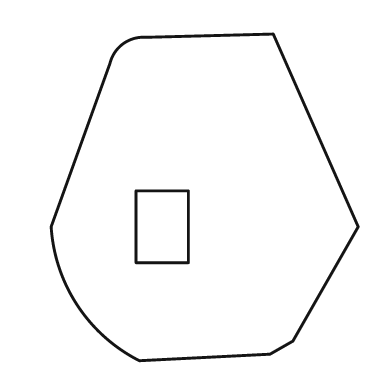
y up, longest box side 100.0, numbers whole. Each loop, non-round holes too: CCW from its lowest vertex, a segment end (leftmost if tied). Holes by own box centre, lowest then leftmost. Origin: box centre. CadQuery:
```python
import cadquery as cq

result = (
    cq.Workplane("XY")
    .moveTo(-20.0, -50.0)
    .lineTo(20.0, -48.0)
    .lineTo(27.0, -44.0)
    .lineTo(47.0, -9.0)
    .lineTo(21.0, 50.0)
    .lineTo(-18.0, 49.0)
    .threePointArc((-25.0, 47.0), (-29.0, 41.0))
    .lineTo(-47.0, -9.0)
    .threePointArc((-39.0, -33.0), (-20.0, -50.0))
    .close()
    .moveTo(-21.0, -20.0)
    .lineTo(-5.0, -20.0)
    .lineTo(-5.0, 2.0)
    .lineTo(-21.0, 2.0)
    .close()
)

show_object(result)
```